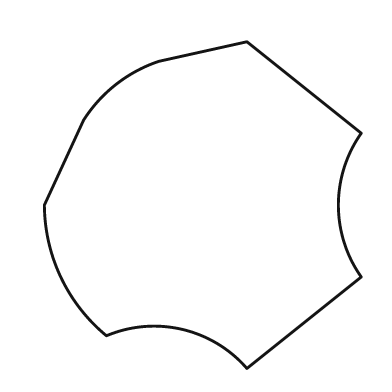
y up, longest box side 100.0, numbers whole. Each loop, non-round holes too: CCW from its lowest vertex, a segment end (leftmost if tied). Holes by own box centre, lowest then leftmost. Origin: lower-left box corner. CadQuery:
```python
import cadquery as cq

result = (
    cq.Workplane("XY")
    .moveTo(62.0, 0.0)
    .lineTo(97.0, 28.0)
    .threePointArc((90.0, 50.0), (97.0, 72.0))
    .lineTo(62.0, 100.0)
    .lineTo(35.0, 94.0)
    .threePointArc((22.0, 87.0), (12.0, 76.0))
    .lineTo(0.0, 50.0)
    .threePointArc((5.0, 28.0), (19.0, 10.0))
    .threePointArc((42.0, 12.0), (62.0, 0.0))
    .close()
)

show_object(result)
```